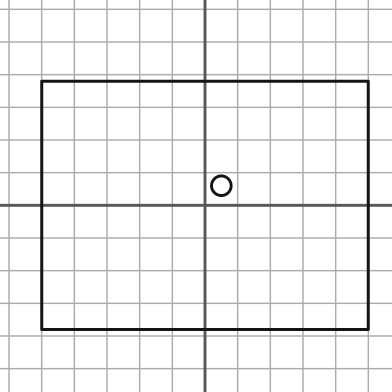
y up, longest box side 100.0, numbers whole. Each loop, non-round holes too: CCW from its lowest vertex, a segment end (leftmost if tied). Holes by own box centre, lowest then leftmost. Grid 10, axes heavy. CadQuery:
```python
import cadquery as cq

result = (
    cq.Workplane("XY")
    .moveTo(-50.0, -38.0)
    .lineTo(50.0, -38.0)
    .lineTo(50.0, 38.0)
    .lineTo(-50.0, 38.0)
    .close()
    .moveTo(5.0, 6.0)
    .circle(3.0)
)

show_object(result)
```